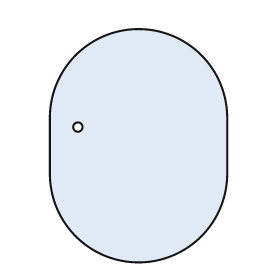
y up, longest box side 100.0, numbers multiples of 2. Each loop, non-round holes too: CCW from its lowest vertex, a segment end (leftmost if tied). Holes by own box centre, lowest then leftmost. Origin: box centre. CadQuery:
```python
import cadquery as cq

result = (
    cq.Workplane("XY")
    .moveTo(-38.0, -12.0)
    .threePointArc((0.0, -50.0), (38.0, -12.0))
    .lineTo(38.0, 12.0)
    .threePointArc((0.0, 50.0), (-38.0, 12.0))
    .close()
    .moveTo(-26.0, 8.0)
    .circle(2.0)
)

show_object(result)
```